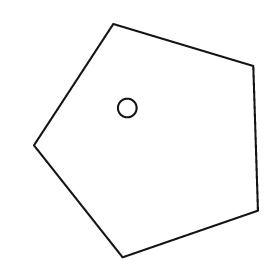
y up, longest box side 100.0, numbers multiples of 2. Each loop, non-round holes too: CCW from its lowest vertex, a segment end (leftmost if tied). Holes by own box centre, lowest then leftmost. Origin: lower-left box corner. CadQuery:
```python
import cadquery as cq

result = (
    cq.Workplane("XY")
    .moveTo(38.0, 0.0)
    .lineTo(96.0, 20.0)
    .lineTo(94.0, 82.0)
    .lineTo(34.0, 100.0)
    .lineTo(0.0, 48.0)
    .close()
    .moveTo(40.0, 64.0)
    .circle(4.0)
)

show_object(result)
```